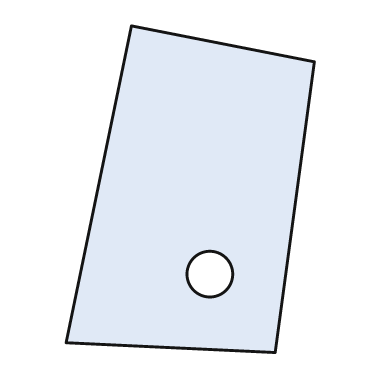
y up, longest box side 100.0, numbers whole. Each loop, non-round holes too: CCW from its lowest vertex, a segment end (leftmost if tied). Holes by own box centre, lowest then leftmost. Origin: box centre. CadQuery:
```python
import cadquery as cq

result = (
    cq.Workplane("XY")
    .moveTo(26.0, -50.0)
    .lineTo(38.0, 39.0)
    .lineTo(-18.0, 50.0)
    .lineTo(-38.0, -47.0)
    .close()
    .moveTo(6.0, -26.0)
    .circle(7.0)
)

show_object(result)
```